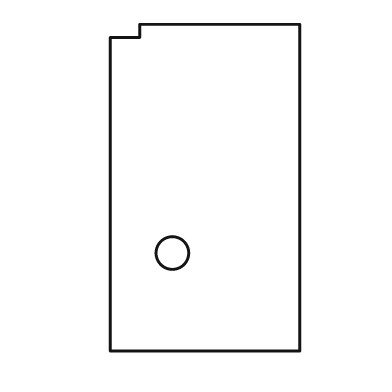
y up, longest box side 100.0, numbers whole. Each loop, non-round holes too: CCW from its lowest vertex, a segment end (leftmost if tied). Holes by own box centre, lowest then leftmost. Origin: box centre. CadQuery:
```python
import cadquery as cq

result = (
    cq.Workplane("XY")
    .moveTo(-29.0, -50.0)
    .lineTo(29.0, -50.0)
    .lineTo(29.0, 50.0)
    .lineTo(-20.0, 50.0)
    .lineTo(-20.0, 46.0)
    .lineTo(-29.0, 46.0)
    .close()
    .moveTo(-10.0, -20.0)
    .circle(5.0)
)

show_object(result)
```